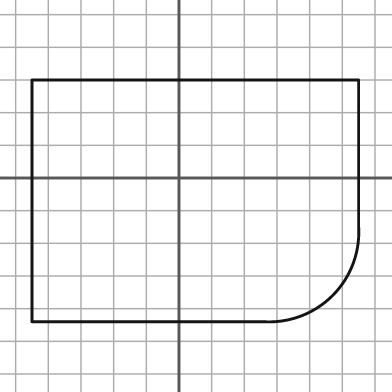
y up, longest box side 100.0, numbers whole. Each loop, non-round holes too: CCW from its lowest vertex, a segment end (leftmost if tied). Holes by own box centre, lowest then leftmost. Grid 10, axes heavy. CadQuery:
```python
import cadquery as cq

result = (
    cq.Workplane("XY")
    .moveTo(-45.0, -44.0)
    .lineTo(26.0, -44.0)
    .threePointArc((47.0, -36.0), (55.0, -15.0))
    .lineTo(55.0, 30.0)
    .lineTo(-45.0, 30.0)
    .close()
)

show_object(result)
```